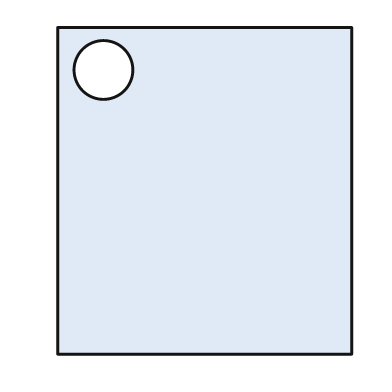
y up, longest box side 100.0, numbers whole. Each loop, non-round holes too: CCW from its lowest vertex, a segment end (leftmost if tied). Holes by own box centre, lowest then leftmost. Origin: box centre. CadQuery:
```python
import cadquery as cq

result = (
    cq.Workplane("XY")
    .moveTo(-45.0, -50.0)
    .lineTo(45.0, -50.0)
    .lineTo(45.0, 50.0)
    .lineTo(-45.0, 50.0)
    .close()
    .moveTo(-31.0, 37.0)
    .circle(9.0)
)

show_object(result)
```